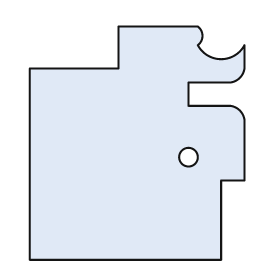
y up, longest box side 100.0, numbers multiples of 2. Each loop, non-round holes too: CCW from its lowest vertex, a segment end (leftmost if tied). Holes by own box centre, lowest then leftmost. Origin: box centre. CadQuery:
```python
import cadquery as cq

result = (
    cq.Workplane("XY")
    .moveTo(-46.0, -50.0)
    .lineTo(36.0, -50.0)
    .lineTo(36.0, -16.0)
    .lineTo(46.0, -16.0)
    .lineTo(46.0, 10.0)
    .threePointArc((44.0, 14.0), (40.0, 16.0))
    .lineTo(22.0, 16.0)
    .lineTo(22.0, 26.0)
    .lineTo(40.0, 26.0)
    .threePointArc((44.0, 28.0), (46.0, 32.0))
    .lineTo(46.0, 42.0)
    .threePointArc((36.0, 36.0), (26.0, 42.0))
    .threePointArc((28.0, 46.0), (26.0, 50.0))
    .lineTo(-8.0, 50.0)
    .lineTo(-8.0, 32.0)
    .lineTo(-46.0, 32.0)
    .close()
    .moveTo(22.0, -6.0)
    .circle(4.0)
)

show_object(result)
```